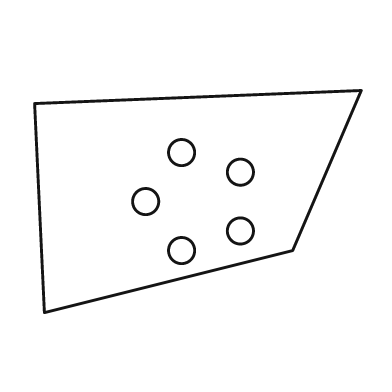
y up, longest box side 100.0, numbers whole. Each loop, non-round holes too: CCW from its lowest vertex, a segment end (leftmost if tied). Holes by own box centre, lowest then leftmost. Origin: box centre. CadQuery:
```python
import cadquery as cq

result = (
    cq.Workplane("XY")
    .moveTo(-47.0, -34.0)
    .lineTo(29.0, -15.0)
    .lineTo(50.0, 34.0)
    .lineTo(-50.0, 30.0)
    .close()
    .moveTo(-5.0, -15.0)
    .circle(4.0)
    .moveTo(13.0, -9.0)
    .circle(4.0)
    .moveTo(-16.0, 0.0)
    .circle(4.0)
    .moveTo(13.0, 9.0)
    .circle(4.0)
    .moveTo(-5.0, 15.0)
    .circle(4.0)
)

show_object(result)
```